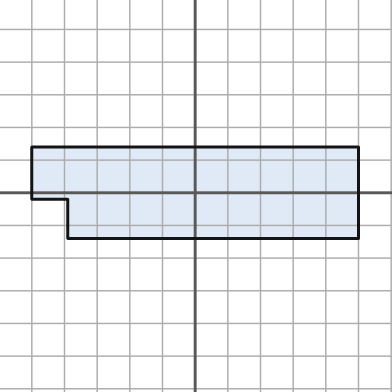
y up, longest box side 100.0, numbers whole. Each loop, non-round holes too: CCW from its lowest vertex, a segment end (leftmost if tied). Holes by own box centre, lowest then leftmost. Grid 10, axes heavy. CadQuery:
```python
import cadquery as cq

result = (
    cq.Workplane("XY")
    .moveTo(-39.0, -14.0)
    .lineTo(50.0, -14.0)
    .lineTo(50.0, 14.0)
    .lineTo(-50.0, 14.0)
    .lineTo(-50.0, -2.0)
    .lineTo(-39.0, -2.0)
    .close()
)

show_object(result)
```